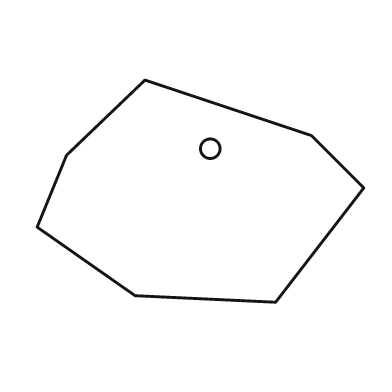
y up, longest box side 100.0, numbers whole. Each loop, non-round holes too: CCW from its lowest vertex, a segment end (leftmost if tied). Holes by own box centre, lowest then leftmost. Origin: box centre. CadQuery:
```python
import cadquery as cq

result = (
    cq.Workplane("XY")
    .moveTo(23.0, -34.0)
    .lineTo(50.0, 1.0)
    .lineTo(34.0, 17.0)
    .lineTo(-17.0, 34.0)
    .lineTo(-41.0, 11.0)
    .lineTo(-50.0, -11.0)
    .lineTo(-20.0, -32.0)
    .close()
    .moveTo(3.0, 13.0)
    .circle(3.0)
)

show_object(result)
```